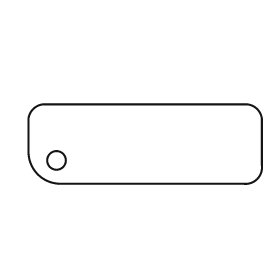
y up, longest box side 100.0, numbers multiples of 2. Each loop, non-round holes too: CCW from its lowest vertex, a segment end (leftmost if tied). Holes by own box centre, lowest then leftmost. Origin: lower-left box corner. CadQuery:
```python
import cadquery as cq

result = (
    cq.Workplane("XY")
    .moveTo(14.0, 0.0)
    .lineTo(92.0, 0.0)
    .threePointArc((98.0, 2.0), (100.0, 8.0))
    .lineTo(100.0, 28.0)
    .threePointArc((98.0, 32.0), (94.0, 34.0))
    .lineTo(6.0, 34.0)
    .threePointArc((2.0, 32.0), (0.0, 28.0))
    .lineTo(0.0, 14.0)
    .threePointArc((4.0, 4.0), (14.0, 0.0))
    .close()
    .moveTo(12.0, 10.0)
    .circle(4.0)
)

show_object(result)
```